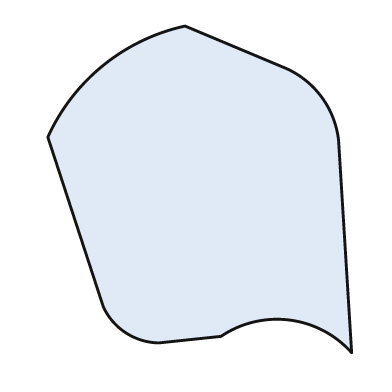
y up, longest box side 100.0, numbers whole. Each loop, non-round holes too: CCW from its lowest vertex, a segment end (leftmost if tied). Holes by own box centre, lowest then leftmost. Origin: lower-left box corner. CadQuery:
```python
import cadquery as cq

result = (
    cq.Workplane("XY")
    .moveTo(93.0, 0.0)
    .lineTo(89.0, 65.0)
    .threePointArc((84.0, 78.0), (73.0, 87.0))
    .lineTo(42.0, 100.0)
    .threePointArc((17.0, 88.0), (0.0, 66.0))
    .lineTo(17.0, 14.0)
    .threePointArc((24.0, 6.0), (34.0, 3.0))
    .lineTo(53.0, 5.0)
    .threePointArc((74.0, 10.0), (93.0, 0.0))
    .close()
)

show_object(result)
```